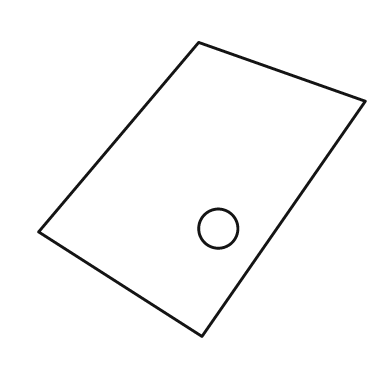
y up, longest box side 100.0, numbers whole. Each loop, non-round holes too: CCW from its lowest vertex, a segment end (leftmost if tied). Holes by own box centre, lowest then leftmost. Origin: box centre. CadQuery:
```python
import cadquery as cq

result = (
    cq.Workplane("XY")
    .moveTo(0.0, -45.0)
    .lineTo(50.0, 27.0)
    .lineTo(-1.0, 45.0)
    .lineTo(-50.0, -13.0)
    .close()
    .moveTo(5.0, -12.0)
    .circle(6.0)
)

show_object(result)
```